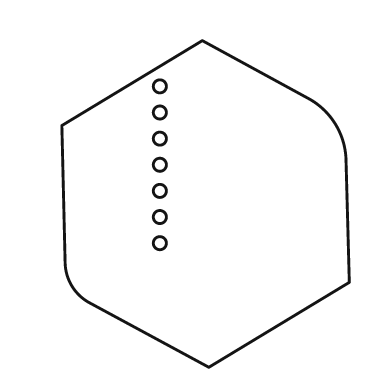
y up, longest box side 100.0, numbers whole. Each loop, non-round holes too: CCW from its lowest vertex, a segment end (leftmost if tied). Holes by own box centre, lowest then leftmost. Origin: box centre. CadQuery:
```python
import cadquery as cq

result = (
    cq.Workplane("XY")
    .moveTo(1.0, -50.0)
    .lineTo(44.0, -24.0)
    .lineTo(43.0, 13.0)
    .threePointArc((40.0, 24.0), (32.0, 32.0))
    .lineTo(-1.0, 50.0)
    .lineTo(-44.0, 24.0)
    .lineTo(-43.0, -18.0)
    .threePointArc((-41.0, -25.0), (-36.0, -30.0))
    .close()
    .moveTo(-14.0, -12.0)
    .circle(2.0)
    .moveTo(-14.0, -4.0)
    .circle(2.0)
    .moveTo(-14.0, 4.0)
    .circle(2.0)
    .moveTo(-14.0, 12.0)
    .circle(2.0)
    .moveTo(-14.0, 20.0)
    .circle(2.0)
    .moveTo(-14.0, 28.0)
    .circle(2.0)
    .moveTo(-14.0, 36.0)
    .circle(2.0)
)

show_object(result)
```